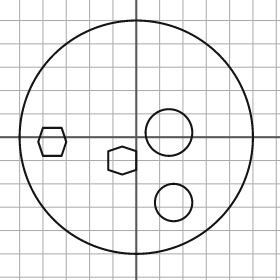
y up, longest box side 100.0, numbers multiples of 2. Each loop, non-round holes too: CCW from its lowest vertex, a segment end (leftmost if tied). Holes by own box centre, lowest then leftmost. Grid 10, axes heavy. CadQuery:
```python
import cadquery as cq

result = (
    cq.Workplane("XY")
    .moveTo(0.0, 0.0)
    .circle(50.0)
    .moveTo(16.0, -28.0)
    .circle(8.0)
    .moveTo(-6.0, -16.0)
    .lineTo(0.0, -14.0)
    .lineTo(0.0, -6.0)
    .lineTo(-6.0, -4.0)
    .lineTo(-12.0, -6.0)
    .lineTo(-12.0, -14.0)
    .close()
    .moveTo(-40.0, -8.0)
    .lineTo(-32.0, -8.0)
    .lineTo(-30.0, -2.0)
    .lineTo(-32.0, 4.0)
    .lineTo(-40.0, 4.0)
    .lineTo(-42.0, -2.0)
    .close()
    .moveTo(14.0, 2.0)
    .circle(10.0)
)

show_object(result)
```